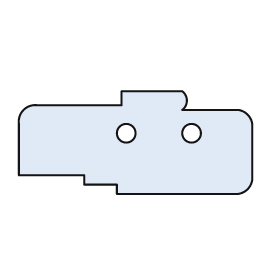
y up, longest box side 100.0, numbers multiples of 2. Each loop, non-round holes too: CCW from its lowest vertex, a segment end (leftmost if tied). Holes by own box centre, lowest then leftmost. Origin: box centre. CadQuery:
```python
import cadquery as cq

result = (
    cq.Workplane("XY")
    .moveTo(-8.0, -22.0)
    .lineTo(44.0, -22.0)
    .threePointArc((48.0, -20.0), (50.0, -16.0))
    .lineTo(50.0, 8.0)
    .threePointArc((48.0, 12.0), (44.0, 14.0))
    .lineTo(20.0, 14.0)
    .threePointArc((22.0, 18.0), (20.0, 22.0))
    .lineTo(-6.0, 22.0)
    .lineTo(-6.0, 16.0)
    .lineTo(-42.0, 16.0)
    .threePointArc((-48.0, 14.0), (-50.0, 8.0))
    .lineTo(-50.0, -14.0)
    .lineTo(-22.0, -14.0)
    .lineTo(-22.0, -18.0)
    .lineTo(-8.0, -18.0)
    .close()
    .moveTo(-4.0, 4.0)
    .circle(4.0)
    .moveTo(24.0, 4.0)
    .circle(4.0)
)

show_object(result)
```